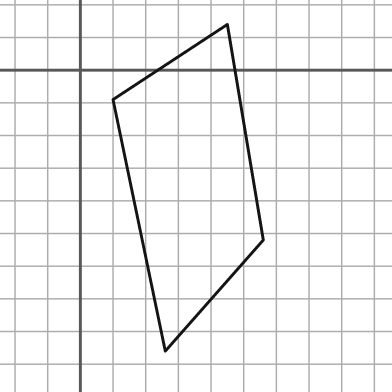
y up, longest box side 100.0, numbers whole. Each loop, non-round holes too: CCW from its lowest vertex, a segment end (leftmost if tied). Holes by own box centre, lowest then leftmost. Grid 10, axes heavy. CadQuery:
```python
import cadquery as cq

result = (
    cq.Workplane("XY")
    .moveTo(26.0, -86.0)
    .lineTo(56.0, -52.0)
    .lineTo(45.0, 14.0)
    .lineTo(10.0, -9.0)
    .close()
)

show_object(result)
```